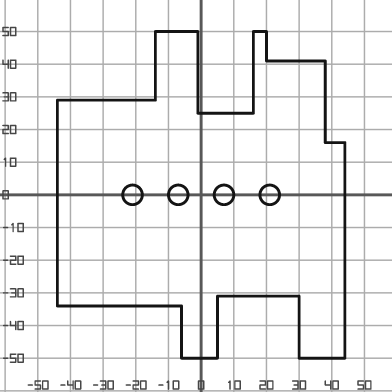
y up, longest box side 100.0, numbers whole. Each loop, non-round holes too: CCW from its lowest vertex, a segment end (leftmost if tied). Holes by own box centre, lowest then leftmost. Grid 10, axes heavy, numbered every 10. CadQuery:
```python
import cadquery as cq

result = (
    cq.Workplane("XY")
    .moveTo(-6.0, -50.0)
    .lineTo(5.0, -50.0)
    .lineTo(5.0, -31.0)
    .lineTo(30.0, -31.0)
    .lineTo(30.0, -50.0)
    .lineTo(44.0, -50.0)
    .lineTo(44.0, 16.0)
    .lineTo(38.0, 16.0)
    .lineTo(38.0, 41.0)
    .lineTo(20.0, 41.0)
    .lineTo(20.0, 50.0)
    .lineTo(16.0, 50.0)
    .lineTo(16.0, 25.0)
    .lineTo(-1.0, 25.0)
    .lineTo(-1.0, 50.0)
    .lineTo(-14.0, 50.0)
    .lineTo(-14.0, 29.0)
    .lineTo(-44.0, 29.0)
    .lineTo(-44.0, -34.0)
    .lineTo(-6.0, -34.0)
    .close()
    .moveTo(-21.0, 0.0)
    .circle(3.0)
    .moveTo(-7.0, 0.0)
    .circle(3.0)
    .moveTo(7.0, 0.0)
    .circle(3.0)
    .moveTo(21.0, 0.0)
    .circle(3.0)
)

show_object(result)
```